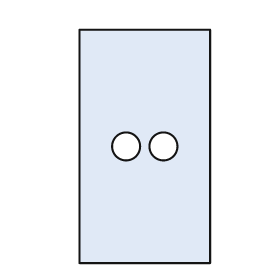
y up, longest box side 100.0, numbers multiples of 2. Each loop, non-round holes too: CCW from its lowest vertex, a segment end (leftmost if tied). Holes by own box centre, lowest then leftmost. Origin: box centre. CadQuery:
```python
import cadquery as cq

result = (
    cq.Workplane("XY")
    .moveTo(-28.0, -50.0)
    .lineTo(28.0, -50.0)
    .lineTo(28.0, 50.0)
    .lineTo(-28.0, 50.0)
    .close()
    .moveTo(-8.0, 0.0)
    .circle(6.0)
    .moveTo(8.0, 0.0)
    .circle(6.0)
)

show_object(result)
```